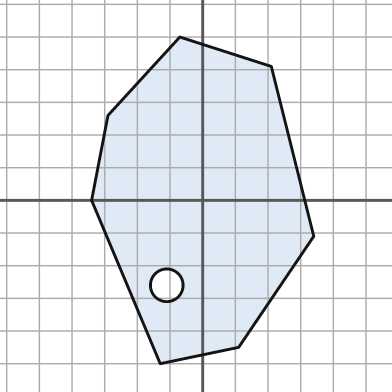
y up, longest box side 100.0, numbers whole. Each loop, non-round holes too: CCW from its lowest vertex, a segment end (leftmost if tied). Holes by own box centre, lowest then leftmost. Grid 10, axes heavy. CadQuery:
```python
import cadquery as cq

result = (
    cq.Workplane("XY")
    .moveTo(-13.0, -50.0)
    .lineTo(11.0, -45.0)
    .lineTo(34.0, -11.0)
    .lineTo(21.0, 41.0)
    .lineTo(-7.0, 50.0)
    .lineTo(-29.0, 26.0)
    .lineTo(-34.0, 0.0)
    .close()
    .moveTo(-11.0, -26.0)
    .circle(5.0)
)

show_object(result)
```